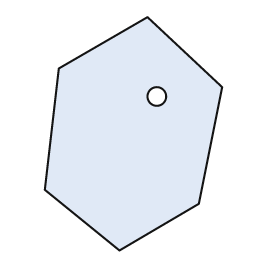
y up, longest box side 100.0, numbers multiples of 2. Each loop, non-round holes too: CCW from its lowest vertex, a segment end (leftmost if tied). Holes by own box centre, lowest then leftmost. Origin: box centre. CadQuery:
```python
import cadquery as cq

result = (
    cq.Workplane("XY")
    .moveTo(-6.0, -50.0)
    .lineTo(28.0, -30.0)
    .lineTo(38.0, 20.0)
    .lineTo(6.0, 50.0)
    .lineTo(-32.0, 28.0)
    .lineTo(-38.0, -24.0)
    .close()
    .moveTo(10.0, 16.0)
    .circle(4.0)
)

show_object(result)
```